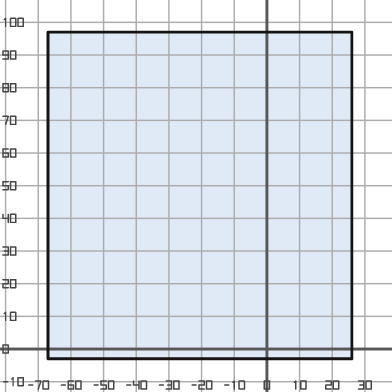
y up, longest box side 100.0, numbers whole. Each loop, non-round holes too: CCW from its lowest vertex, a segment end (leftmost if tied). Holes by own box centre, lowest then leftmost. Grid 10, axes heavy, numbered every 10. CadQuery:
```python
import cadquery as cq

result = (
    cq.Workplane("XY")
    .moveTo(-67.0, -3.0)
    .lineTo(26.0, -3.0)
    .lineTo(26.0, 97.0)
    .lineTo(-67.0, 97.0)
    .close()
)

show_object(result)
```